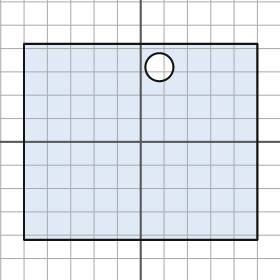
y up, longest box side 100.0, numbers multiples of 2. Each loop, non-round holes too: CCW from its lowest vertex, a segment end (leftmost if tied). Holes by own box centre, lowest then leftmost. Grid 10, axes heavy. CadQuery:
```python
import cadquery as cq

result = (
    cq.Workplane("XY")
    .moveTo(-50.0, -42.0)
    .lineTo(50.0, -42.0)
    .lineTo(50.0, 42.0)
    .lineTo(-50.0, 42.0)
    .close()
    .moveTo(8.0, 32.0)
    .circle(6.0)
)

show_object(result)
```